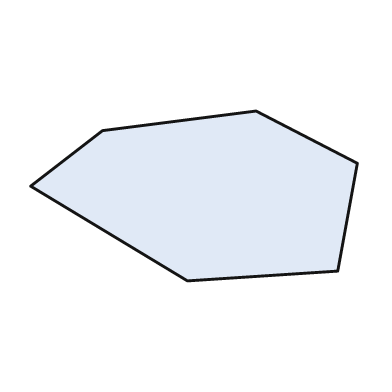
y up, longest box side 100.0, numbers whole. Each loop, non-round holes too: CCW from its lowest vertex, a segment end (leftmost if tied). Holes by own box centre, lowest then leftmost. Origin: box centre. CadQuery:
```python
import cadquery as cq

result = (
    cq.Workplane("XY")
    .moveTo(-2.0, -26.0)
    .lineTo(44.0, -23.0)
    .lineTo(50.0, 10.0)
    .lineTo(19.0, 26.0)
    .lineTo(-28.0, 20.0)
    .lineTo(-50.0, 3.0)
    .close()
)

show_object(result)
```